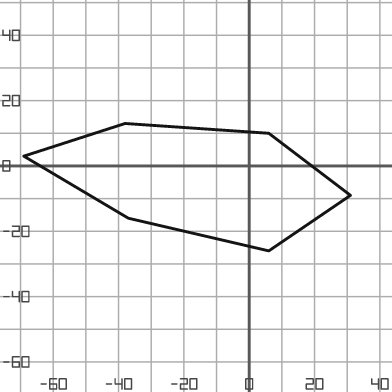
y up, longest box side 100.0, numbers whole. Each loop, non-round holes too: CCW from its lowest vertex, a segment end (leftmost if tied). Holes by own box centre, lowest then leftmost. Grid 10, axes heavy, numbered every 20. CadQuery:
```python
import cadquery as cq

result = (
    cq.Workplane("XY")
    .moveTo(6.0, -26.0)
    .lineTo(31.0, -9.0)
    .lineTo(6.0, 10.0)
    .lineTo(-38.0, 13.0)
    .lineTo(-69.0, 3.0)
    .lineTo(-37.0, -16.0)
    .close()
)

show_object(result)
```